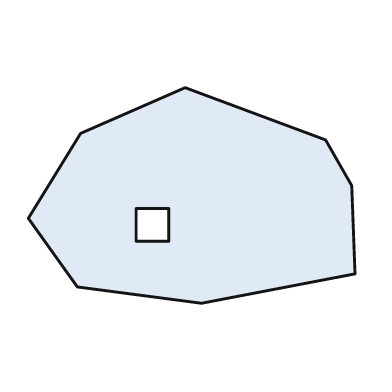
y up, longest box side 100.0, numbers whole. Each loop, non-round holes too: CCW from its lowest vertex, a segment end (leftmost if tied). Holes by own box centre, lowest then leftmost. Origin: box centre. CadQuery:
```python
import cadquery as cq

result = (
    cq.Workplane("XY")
    .moveTo(3.0, -33.0)
    .lineTo(50.0, -24.0)
    .lineTo(49.0, 3.0)
    .lineTo(41.0, 17.0)
    .lineTo(-2.0, 33.0)
    .lineTo(-34.0, 19.0)
    .lineTo(-50.0, -7.0)
    .lineTo(-35.0, -28.0)
    .close()
    .moveTo(-17.0, -14.0)
    .lineTo(-7.0, -14.0)
    .lineTo(-7.0, -4.0)
    .lineTo(-17.0, -4.0)
    .close()
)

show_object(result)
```